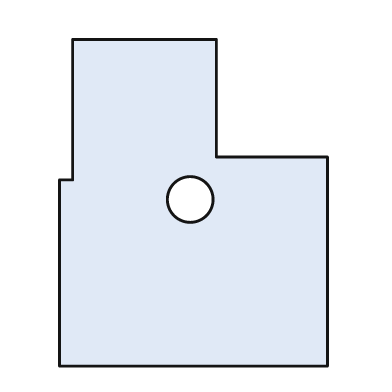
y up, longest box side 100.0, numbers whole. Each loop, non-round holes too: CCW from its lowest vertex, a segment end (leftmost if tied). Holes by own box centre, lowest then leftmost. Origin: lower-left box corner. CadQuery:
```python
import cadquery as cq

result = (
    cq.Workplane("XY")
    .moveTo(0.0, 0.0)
    .lineTo(82.0, 0.0)
    .lineTo(82.0, 64.0)
    .lineTo(48.0, 64.0)
    .lineTo(48.0, 100.0)
    .lineTo(4.0, 100.0)
    .lineTo(4.0, 57.0)
    .lineTo(0.0, 57.0)
    .close()
    .moveTo(40.0, 51.0)
    .circle(7.0)
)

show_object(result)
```